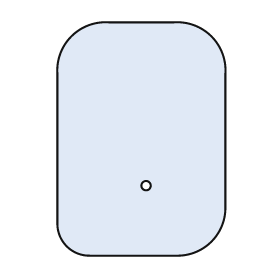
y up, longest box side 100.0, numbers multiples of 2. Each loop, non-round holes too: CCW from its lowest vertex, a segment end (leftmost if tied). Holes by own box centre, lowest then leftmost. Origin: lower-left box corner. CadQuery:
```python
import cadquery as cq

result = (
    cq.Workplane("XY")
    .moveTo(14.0, 0.0)
    .lineTo(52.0, 0.0)
    .threePointArc((66.0, 6.0), (72.0, 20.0))
    .lineTo(72.0, 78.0)
    .threePointArc((66.0, 94.0), (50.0, 100.0))
    .lineTo(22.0, 100.0)
    .threePointArc((6.0, 94.0), (0.0, 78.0))
    .lineTo(0.0, 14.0)
    .threePointArc((4.0, 4.0), (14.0, 0.0))
    .close()
    .moveTo(38.0, 30.0)
    .circle(2.0)
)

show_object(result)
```